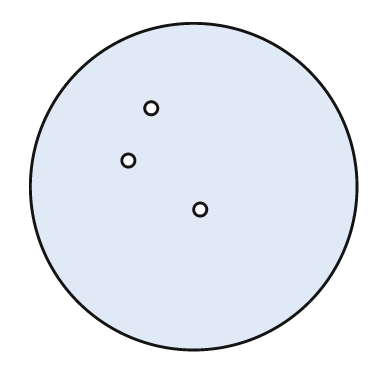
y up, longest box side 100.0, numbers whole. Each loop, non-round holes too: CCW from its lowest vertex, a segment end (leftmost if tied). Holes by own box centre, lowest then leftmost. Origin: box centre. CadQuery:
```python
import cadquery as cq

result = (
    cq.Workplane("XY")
    .moveTo(0.0, 0.0)
    .circle(50.0)
    .moveTo(2.0, -7.0)
    .circle(2.0)
    .moveTo(-20.0, 8.0)
    .circle(2.0)
    .moveTo(-13.0, 24.0)
    .circle(2.0)
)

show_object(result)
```